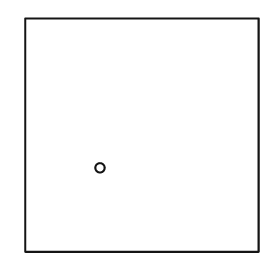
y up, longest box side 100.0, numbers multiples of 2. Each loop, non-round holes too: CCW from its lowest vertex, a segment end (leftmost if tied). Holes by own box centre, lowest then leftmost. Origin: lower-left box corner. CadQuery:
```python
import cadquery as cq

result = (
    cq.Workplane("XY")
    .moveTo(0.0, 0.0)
    .lineTo(100.0, 0.0)
    .lineTo(100.0, 100.0)
    .lineTo(0.0, 100.0)
    .close()
    .moveTo(32.0, 36.0)
    .circle(2.0)
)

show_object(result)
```